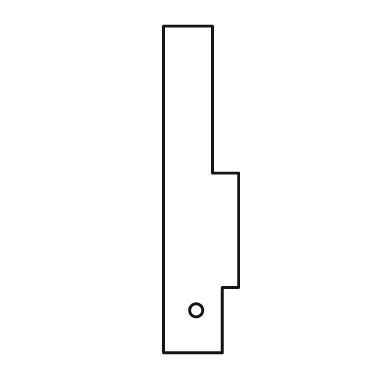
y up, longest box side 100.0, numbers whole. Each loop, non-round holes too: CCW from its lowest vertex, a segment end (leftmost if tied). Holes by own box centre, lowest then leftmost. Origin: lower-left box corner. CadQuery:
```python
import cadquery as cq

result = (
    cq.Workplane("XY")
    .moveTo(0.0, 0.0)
    .lineTo(18.0, 0.0)
    .lineTo(18.0, 20.0)
    .lineTo(23.0, 20.0)
    .lineTo(23.0, 55.0)
    .lineTo(15.0, 55.0)
    .lineTo(15.0, 100.0)
    .lineTo(0.0, 100.0)
    .close()
    .moveTo(10.0, 13.0)
    .circle(2.0)
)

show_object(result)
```